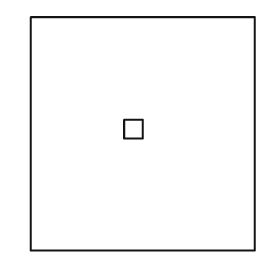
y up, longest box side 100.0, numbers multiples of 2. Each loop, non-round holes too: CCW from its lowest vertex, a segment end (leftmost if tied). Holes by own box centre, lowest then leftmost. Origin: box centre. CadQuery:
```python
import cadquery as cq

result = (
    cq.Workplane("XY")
    .moveTo(-48.0, -50.0)
    .lineTo(48.0, -50.0)
    .lineTo(48.0, 50.0)
    .lineTo(-48.0, 50.0)
    .close()
    .moveTo(-8.0, -2.0)
    .lineTo(0.0, -2.0)
    .lineTo(0.0, 6.0)
    .lineTo(-8.0, 6.0)
    .close()
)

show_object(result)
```